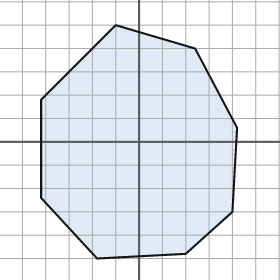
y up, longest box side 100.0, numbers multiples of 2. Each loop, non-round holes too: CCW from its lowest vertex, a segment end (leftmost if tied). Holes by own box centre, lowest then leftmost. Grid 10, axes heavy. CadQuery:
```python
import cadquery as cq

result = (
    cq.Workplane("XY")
    .moveTo(-18.0, -50.0)
    .lineTo(20.0, -48.0)
    .lineTo(40.0, -30.0)
    .lineTo(42.0, 6.0)
    .lineTo(24.0, 40.0)
    .lineTo(-10.0, 50.0)
    .lineTo(-42.0, 18.0)
    .lineTo(-42.0, -24.0)
    .close()
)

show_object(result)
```